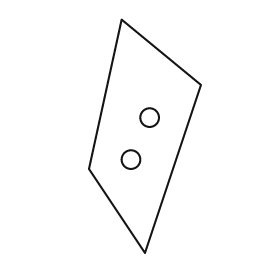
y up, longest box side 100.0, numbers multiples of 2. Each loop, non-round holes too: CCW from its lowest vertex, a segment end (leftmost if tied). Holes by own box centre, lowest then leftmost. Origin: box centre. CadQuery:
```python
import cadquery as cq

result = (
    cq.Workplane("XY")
    .moveTo(0.0, -50.0)
    .lineTo(24.0, 22.0)
    .lineTo(-10.0, 50.0)
    .lineTo(-24.0, -14.0)
    .close()
    .moveTo(-6.0, -10.0)
    .circle(4.0)
    .moveTo(2.0, 8.0)
    .circle(4.0)
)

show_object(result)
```